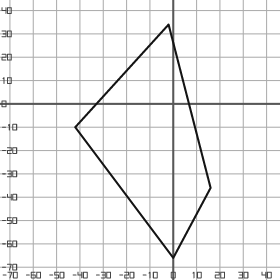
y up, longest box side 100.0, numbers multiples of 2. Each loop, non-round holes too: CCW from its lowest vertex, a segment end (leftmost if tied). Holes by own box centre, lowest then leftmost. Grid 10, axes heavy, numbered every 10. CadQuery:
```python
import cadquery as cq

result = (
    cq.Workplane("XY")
    .moveTo(0.0, -66.0)
    .lineTo(16.0, -36.0)
    .lineTo(-2.0, 34.0)
    .lineTo(-42.0, -10.0)
    .close()
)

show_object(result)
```